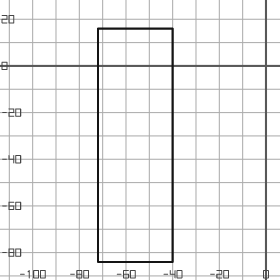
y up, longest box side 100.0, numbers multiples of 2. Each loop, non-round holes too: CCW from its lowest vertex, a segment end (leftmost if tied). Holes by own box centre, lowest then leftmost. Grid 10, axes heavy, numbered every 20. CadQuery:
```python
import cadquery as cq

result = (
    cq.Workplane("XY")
    .moveTo(-72.0, -84.0)
    .lineTo(-40.0, -84.0)
    .lineTo(-40.0, 16.0)
    .lineTo(-72.0, 16.0)
    .close()
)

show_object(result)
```